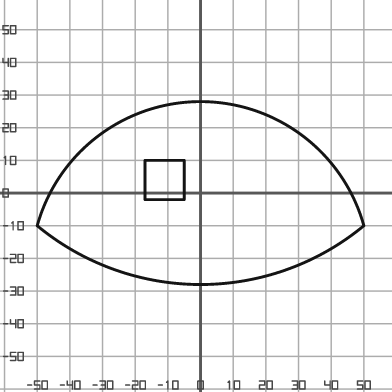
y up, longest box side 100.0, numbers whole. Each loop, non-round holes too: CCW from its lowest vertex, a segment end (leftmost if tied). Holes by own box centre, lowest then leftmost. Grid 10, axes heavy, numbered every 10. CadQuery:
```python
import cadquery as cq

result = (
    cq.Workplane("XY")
    .moveTo(-50.0, -10.0)
    .threePointArc((0.0, -28.0), (50.0, -10.0))
    .threePointArc((0.0, 28.0), (-50.0, -10.0))
    .close()
    .moveTo(-17.0, -2.0)
    .lineTo(-5.0, -2.0)
    .lineTo(-5.0, 10.0)
    .lineTo(-17.0, 10.0)
    .close()
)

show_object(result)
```